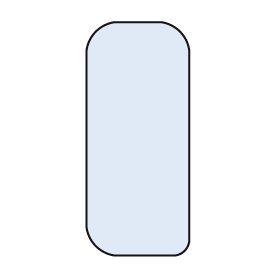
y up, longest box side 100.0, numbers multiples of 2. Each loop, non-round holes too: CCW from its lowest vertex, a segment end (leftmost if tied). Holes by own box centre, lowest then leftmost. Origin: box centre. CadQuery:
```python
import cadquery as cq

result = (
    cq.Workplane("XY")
    .moveTo(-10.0, -50.0)
    .lineTo(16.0, -50.0)
    .threePointArc((20.0, -48.0), (22.0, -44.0))
    .lineTo(22.0, 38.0)
    .threePointArc((18.0, 46.0), (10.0, 50.0))
    .lineTo(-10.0, 50.0)
    .threePointArc((-18.0, 46.0), (-22.0, 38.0))
    .lineTo(-22.0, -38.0)
    .threePointArc((-18.0, -46.0), (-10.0, -50.0))
    .close()
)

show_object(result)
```